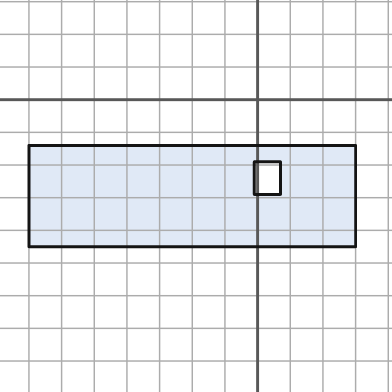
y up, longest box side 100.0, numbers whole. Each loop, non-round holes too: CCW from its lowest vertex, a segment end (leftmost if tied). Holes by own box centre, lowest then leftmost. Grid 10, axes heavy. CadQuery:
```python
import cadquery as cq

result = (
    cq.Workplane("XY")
    .moveTo(-70.0, -45.0)
    .lineTo(30.0, -45.0)
    .lineTo(30.0, -14.0)
    .lineTo(-70.0, -14.0)
    .close()
    .moveTo(-1.0, -29.0)
    .lineTo(7.0, -29.0)
    .lineTo(7.0, -19.0)
    .lineTo(-1.0, -19.0)
    .close()
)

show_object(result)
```